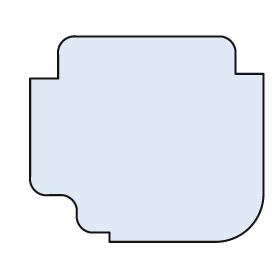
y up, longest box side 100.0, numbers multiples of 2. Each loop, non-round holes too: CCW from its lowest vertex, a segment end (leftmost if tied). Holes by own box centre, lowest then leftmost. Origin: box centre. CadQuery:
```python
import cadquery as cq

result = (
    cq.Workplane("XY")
    .moveTo(-16.0, -44.0)
    .lineTo(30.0, -44.0)
    .threePointArc((44.0, -38.0), (50.0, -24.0))
    .lineTo(50.0, 28.0)
    .lineTo(38.0, 28.0)
    .lineTo(38.0, 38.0)
    .threePointArc((36.0, 42.0), (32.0, 44.0))
    .lineTo(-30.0, 44.0)
    .threePointArc((-36.0, 42.0), (-38.0, 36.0))
    .lineTo(-38.0, 26.0)
    .lineTo(-50.0, 26.0)
    .lineTo(-50.0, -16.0)
    .threePointArc((-48.0, -22.0), (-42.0, -24.0))
    .lineTo(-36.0, -24.0)
    .threePointArc((-32.0, -26.0), (-30.0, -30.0))
    .lineTo(-30.0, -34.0)
    .threePointArc((-28.0, -38.0), (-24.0, -40.0))
    .lineTo(-16.0, -40.0)
    .close()
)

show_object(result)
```